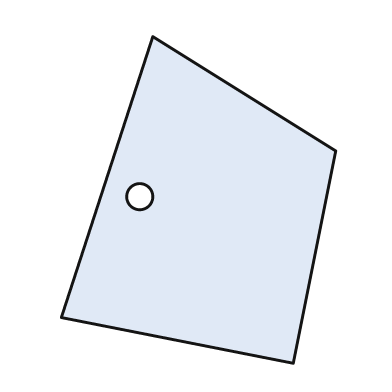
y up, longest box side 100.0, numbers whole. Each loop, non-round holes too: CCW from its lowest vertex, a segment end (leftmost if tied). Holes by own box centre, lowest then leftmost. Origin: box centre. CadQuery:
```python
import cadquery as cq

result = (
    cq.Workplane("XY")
    .moveTo(29.0, -50.0)
    .lineTo(42.0, 15.0)
    .lineTo(-14.0, 50.0)
    .lineTo(-42.0, -36.0)
    .close()
    .moveTo(-18.0, 1.0)
    .circle(4.0)
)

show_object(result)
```